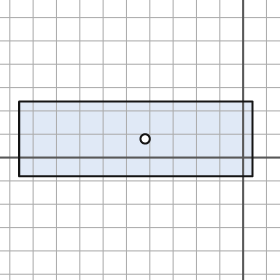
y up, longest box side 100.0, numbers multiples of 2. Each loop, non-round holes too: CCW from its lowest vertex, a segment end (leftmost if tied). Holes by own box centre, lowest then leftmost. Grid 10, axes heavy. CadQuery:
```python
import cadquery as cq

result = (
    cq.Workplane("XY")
    .moveTo(-96.0, -8.0)
    .lineTo(4.0, -8.0)
    .lineTo(4.0, 24.0)
    .lineTo(-96.0, 24.0)
    .close()
    .moveTo(-42.0, 8.0)
    .circle(2.0)
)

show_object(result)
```